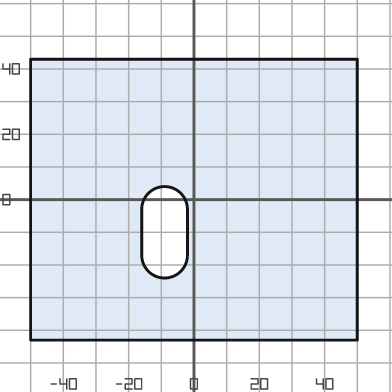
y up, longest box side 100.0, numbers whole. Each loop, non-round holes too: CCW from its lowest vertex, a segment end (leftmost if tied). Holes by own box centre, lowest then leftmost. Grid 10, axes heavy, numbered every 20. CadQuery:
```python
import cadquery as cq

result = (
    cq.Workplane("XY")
    .moveTo(-50.0, -43.0)
    .lineTo(50.0, -43.0)
    .lineTo(50.0, 43.0)
    .lineTo(-50.0, 43.0)
    .close()
    .moveTo(-16.0, -17.0)
    .threePointArc((-9.0, -24.0), (-2.0, -17.0))
    .lineTo(-2.0, -3.0)
    .threePointArc((-9.0, 4.0), (-16.0, -3.0))
    .close()
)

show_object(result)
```